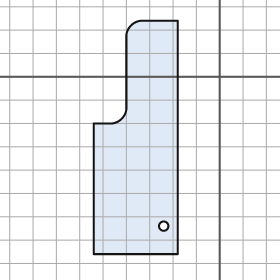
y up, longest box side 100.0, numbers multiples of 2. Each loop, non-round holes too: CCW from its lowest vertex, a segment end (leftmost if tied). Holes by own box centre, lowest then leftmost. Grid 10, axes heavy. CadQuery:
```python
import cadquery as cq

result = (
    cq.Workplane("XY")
    .moveTo(-54.0, -76.0)
    .lineTo(-18.0, -76.0)
    .lineTo(-18.0, 24.0)
    .lineTo(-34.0, 24.0)
    .threePointArc((-38.0, 22.0), (-40.0, 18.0))
    .lineTo(-40.0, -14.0)
    .threePointArc((-42.0, -18.0), (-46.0, -20.0))
    .lineTo(-54.0, -20.0)
    .close()
    .moveTo(-24.0, -64.0)
    .circle(2.0)
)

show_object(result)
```